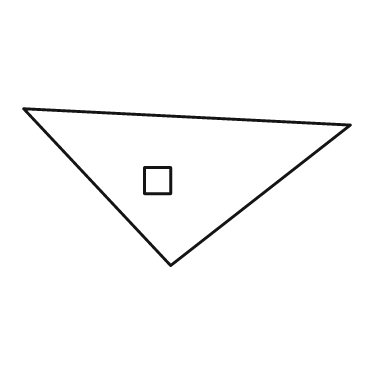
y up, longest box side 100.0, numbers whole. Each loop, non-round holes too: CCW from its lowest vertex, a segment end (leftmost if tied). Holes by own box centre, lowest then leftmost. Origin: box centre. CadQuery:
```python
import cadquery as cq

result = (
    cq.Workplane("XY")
    .moveTo(-5.0, -24.0)
    .lineTo(50.0, 19.0)
    .lineTo(-50.0, 24.0)
    .close()
    .moveTo(-13.0, -2.0)
    .lineTo(-5.0, -2.0)
    .lineTo(-5.0, 6.0)
    .lineTo(-13.0, 6.0)
    .close()
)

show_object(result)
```